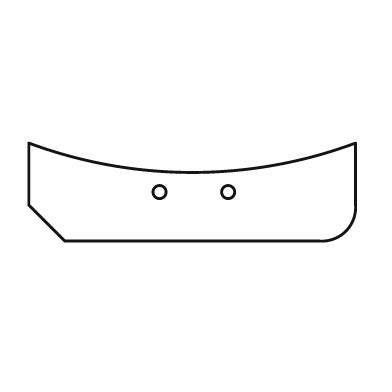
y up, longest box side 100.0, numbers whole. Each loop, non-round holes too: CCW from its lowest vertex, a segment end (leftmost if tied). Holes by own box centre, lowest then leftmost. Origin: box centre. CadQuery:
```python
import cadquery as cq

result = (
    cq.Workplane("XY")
    .moveTo(-39.0, -15.0)
    .lineTo(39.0, -15.0)
    .threePointArc((47.0, -12.0), (50.0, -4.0))
    .lineTo(50.0, 15.0)
    .threePointArc((0.0, 6.0), (-50.0, 15.0))
    .lineTo(-50.0, -4.0)
    .close()
    .moveTo(-10.0, 0.0)
    .circle(2.0)
    .moveTo(11.0, 0.0)
    .circle(2.0)
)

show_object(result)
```